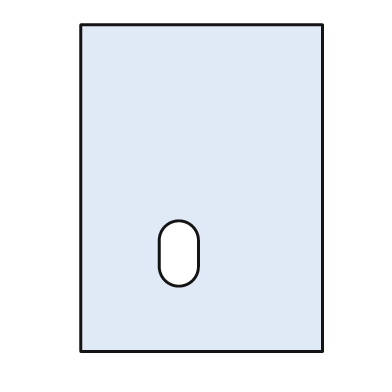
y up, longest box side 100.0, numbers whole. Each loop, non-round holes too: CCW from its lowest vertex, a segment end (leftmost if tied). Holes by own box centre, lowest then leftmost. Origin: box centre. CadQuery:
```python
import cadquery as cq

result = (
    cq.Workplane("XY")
    .moveTo(-37.0, -50.0)
    .lineTo(37.0, -50.0)
    .lineTo(37.0, 50.0)
    .lineTo(-37.0, 50.0)
    .close()
    .moveTo(-13.0, -24.0)
    .threePointArc((-7.0, -30.0), (-1.0, -24.0))
    .lineTo(-1.0, -16.0)
    .threePointArc((-7.0, -10.0), (-13.0, -16.0))
    .close()
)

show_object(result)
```